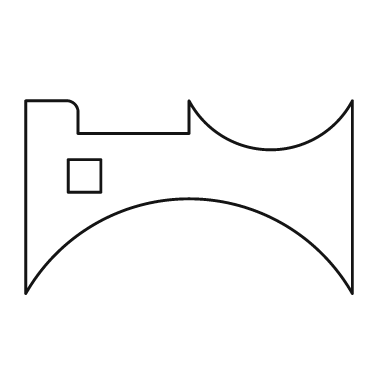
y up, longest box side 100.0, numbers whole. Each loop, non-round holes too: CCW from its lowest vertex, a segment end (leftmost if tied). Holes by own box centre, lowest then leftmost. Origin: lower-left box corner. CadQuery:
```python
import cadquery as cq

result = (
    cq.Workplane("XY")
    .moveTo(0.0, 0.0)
    .threePointArc((50.0, 29.0), (100.0, 0.0))
    .lineTo(100.0, 59.0)
    .threePointArc((75.0, 44.0), (50.0, 59.0))
    .lineTo(50.0, 49.0)
    .lineTo(16.0, 49.0)
    .lineTo(16.0, 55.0)
    .threePointArc((15.0, 58.0), (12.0, 59.0))
    .lineTo(0.0, 59.0)
    .close()
    .moveTo(13.0, 31.0)
    .lineTo(23.0, 31.0)
    .lineTo(23.0, 41.0)
    .lineTo(13.0, 41.0)
    .close()
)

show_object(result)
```